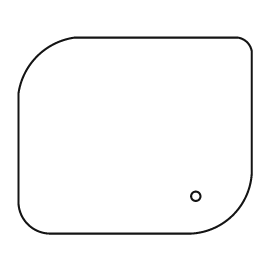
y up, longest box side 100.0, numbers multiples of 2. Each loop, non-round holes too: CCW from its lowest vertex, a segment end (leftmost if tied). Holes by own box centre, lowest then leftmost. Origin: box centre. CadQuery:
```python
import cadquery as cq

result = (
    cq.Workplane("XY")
    .moveTo(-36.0, -42.0)
    .lineTo(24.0, -42.0)
    .threePointArc((42.0, -34.0), (50.0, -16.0))
    .lineTo(50.0, 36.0)
    .threePointArc((48.0, 40.0), (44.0, 42.0))
    .lineTo(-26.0, 42.0)
    .threePointArc((-42.0, 34.0), (-50.0, 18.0))
    .lineTo(-50.0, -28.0)
    .threePointArc((-46.0, -38.0), (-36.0, -42.0))
    .close()
    .moveTo(26.0, -26.0)
    .circle(2.0)
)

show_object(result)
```